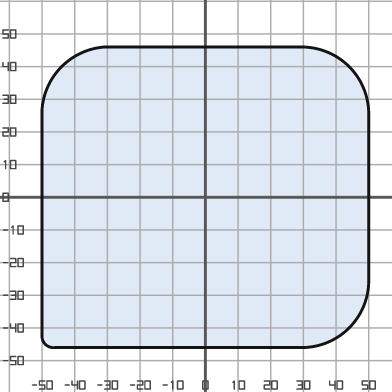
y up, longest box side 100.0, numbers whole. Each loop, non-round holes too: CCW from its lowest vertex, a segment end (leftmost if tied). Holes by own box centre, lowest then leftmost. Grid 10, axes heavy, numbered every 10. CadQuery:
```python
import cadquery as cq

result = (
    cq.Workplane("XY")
    .moveTo(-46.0, -46.0)
    .lineTo(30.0, -46.0)
    .threePointArc((44.0, -40.0), (50.0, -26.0))
    .lineTo(50.0, 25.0)
    .threePointArc((44.0, 40.0), (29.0, 46.0))
    .lineTo(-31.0, 46.0)
    .threePointArc((-44.0, 40.0), (-50.0, 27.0))
    .lineTo(-50.0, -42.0)
    .threePointArc((-49.0, -45.0), (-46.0, -46.0))
    .close()
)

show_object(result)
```